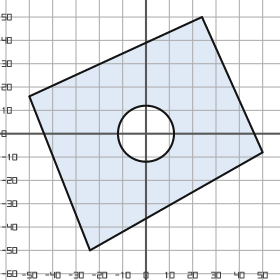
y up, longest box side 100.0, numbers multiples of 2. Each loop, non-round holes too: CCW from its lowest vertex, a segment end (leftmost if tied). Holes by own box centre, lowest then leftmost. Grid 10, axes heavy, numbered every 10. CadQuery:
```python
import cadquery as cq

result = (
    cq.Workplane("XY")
    .moveTo(-24.0, -50.0)
    .lineTo(50.0, -8.0)
    .lineTo(24.0, 50.0)
    .lineTo(-50.0, 16.0)
    .close()
    .moveTo(0.0, 0.0)
    .circle(12.0)
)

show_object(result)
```